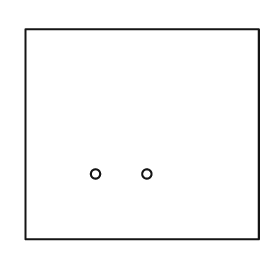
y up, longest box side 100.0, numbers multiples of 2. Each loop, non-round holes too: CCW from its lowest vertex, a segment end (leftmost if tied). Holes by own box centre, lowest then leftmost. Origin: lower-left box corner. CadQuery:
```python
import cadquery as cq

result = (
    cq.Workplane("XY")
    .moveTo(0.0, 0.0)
    .lineTo(100.0, 0.0)
    .lineTo(100.0, 90.0)
    .lineTo(0.0, 90.0)
    .close()
    .moveTo(30.0, 28.0)
    .circle(2.0)
    .moveTo(52.0, 28.0)
    .circle(2.0)
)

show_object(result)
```